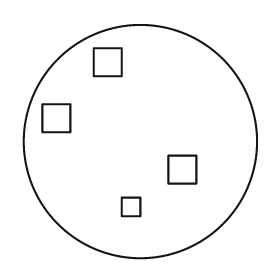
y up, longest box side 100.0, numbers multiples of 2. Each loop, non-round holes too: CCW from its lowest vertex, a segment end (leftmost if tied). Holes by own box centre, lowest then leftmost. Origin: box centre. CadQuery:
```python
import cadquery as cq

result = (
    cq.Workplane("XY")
    .moveTo(0.0, 0.0)
    .circle(50.0)
    .moveTo(-8.0, -32.0)
    .lineTo(0.0, -32.0)
    .lineTo(0.0, -24.0)
    .lineTo(-8.0, -24.0)
    .close()
    .moveTo(12.0, -18.0)
    .lineTo(24.0, -18.0)
    .lineTo(24.0, -6.0)
    .lineTo(12.0, -6.0)
    .close()
    .moveTo(-42.0, 4.0)
    .lineTo(-30.0, 4.0)
    .lineTo(-30.0, 16.0)
    .lineTo(-42.0, 16.0)
    .close()
    .moveTo(-20.0, 28.0)
    .lineTo(-8.0, 28.0)
    .lineTo(-8.0, 40.0)
    .lineTo(-20.0, 40.0)
    .close()
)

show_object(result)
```